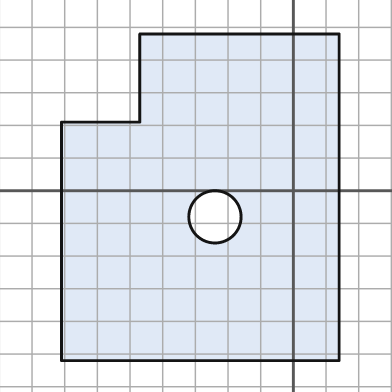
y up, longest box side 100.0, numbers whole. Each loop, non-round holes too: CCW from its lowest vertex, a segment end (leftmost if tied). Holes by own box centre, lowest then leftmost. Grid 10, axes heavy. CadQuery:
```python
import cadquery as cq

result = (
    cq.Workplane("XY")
    .moveTo(-71.0, -52.0)
    .lineTo(14.0, -52.0)
    .lineTo(14.0, 48.0)
    .lineTo(-47.0, 48.0)
    .lineTo(-47.0, 21.0)
    .lineTo(-71.0, 21.0)
    .close()
    .moveTo(-24.0, -8.0)
    .circle(8.0)
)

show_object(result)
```